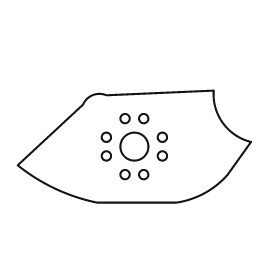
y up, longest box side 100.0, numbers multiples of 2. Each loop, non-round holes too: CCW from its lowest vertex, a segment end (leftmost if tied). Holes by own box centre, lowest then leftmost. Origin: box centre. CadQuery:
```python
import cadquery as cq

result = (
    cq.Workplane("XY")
    .moveTo(-16.0, -24.0)
    .lineTo(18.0, -24.0)
    .threePointArc((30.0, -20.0), (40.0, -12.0))
    .lineTo(50.0, 2.0)
    .threePointArc((38.0, 10.0), (34.0, 24.0))
    .lineTo(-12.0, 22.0)
    .threePointArc((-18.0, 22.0), (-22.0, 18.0))
    .lineTo(-50.0, -8.0)
    .threePointArc((-34.0, -18.0), (-16.0, -24.0))
    .close()
    .moveTo(-4.0, -12.0)
    .circle(2.0)
    .moveTo(4.0, -12.0)
    .circle(2.0)
    .moveTo(-12.0, -4.0)
    .circle(2.0)
    .moveTo(12.0, -4.0)
    .circle(2.0)
    .moveTo(0.0, 0.0)
    .circle(6.0)
    .moveTo(-12.0, 4.0)
    .circle(2.0)
    .moveTo(12.0, 4.0)
    .circle(2.0)
    .moveTo(-4.0, 12.0)
    .circle(2.0)
    .moveTo(4.0, 12.0)
    .circle(2.0)
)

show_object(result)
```